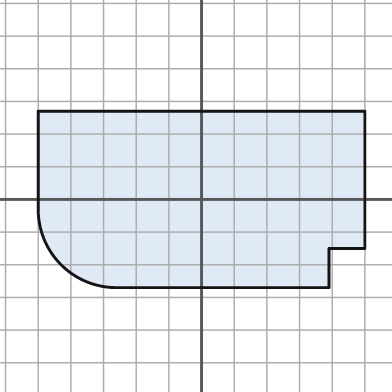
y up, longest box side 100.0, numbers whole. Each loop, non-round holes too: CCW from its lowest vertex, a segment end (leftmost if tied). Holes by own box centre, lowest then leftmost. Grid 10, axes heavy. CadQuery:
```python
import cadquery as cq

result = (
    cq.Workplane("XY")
    .moveTo(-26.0, -27.0)
    .lineTo(39.0, -27.0)
    .lineTo(39.0, -15.0)
    .lineTo(50.0, -15.0)
    .lineTo(50.0, 27.0)
    .lineTo(-50.0, 27.0)
    .lineTo(-50.0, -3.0)
    .threePointArc((-43.0, -20.0), (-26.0, -27.0))
    .close()
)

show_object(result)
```